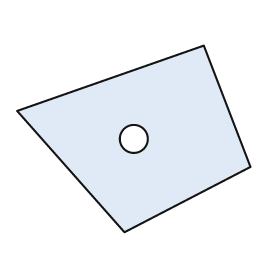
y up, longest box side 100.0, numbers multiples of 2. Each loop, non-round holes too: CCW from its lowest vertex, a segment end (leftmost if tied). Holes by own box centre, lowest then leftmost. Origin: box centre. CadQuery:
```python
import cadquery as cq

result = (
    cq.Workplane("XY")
    .moveTo(-4.0, -40.0)
    .lineTo(50.0, -12.0)
    .lineTo(30.0, 40.0)
    .lineTo(-50.0, 12.0)
    .close()
    .moveTo(0.0, 0.0)
    .circle(6.0)
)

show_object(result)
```